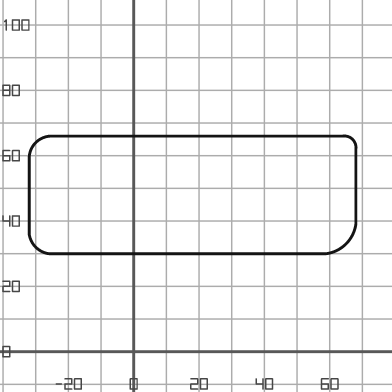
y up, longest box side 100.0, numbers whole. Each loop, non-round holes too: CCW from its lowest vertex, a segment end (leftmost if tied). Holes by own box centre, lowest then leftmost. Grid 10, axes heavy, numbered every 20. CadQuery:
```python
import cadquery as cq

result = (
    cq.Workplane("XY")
    .moveTo(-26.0, 30.0)
    .lineTo(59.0, 30.0)
    .threePointArc((65.0, 33.0), (68.0, 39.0))
    .lineTo(68.0, 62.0)
    .threePointArc((67.0, 65.0), (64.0, 66.0))
    .lineTo(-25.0, 66.0)
    .threePointArc((-30.0, 64.0), (-32.0, 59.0))
    .lineTo(-32.0, 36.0)
    .threePointArc((-30.0, 32.0), (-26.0, 30.0))
    .close()
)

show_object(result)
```